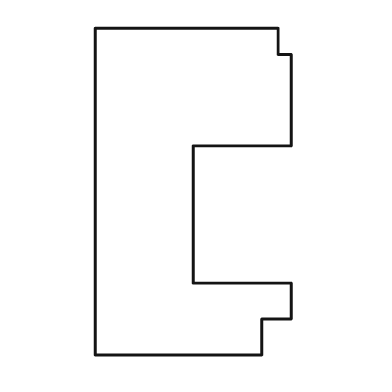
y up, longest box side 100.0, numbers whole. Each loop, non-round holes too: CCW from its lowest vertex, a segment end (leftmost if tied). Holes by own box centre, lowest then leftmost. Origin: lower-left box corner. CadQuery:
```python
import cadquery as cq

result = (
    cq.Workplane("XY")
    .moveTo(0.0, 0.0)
    .lineTo(51.0, 0.0)
    .lineTo(51.0, 11.0)
    .lineTo(60.0, 11.0)
    .lineTo(60.0, 22.0)
    .lineTo(30.0, 22.0)
    .lineTo(30.0, 64.0)
    .lineTo(60.0, 64.0)
    .lineTo(60.0, 92.0)
    .lineTo(56.0, 92.0)
    .lineTo(56.0, 100.0)
    .lineTo(0.0, 100.0)
    .close()
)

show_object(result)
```